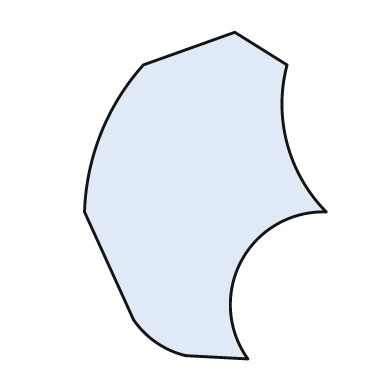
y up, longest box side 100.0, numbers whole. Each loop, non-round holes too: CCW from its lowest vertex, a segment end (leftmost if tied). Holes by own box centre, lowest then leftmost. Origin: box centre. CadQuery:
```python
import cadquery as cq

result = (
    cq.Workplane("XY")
    .moveTo(13.0, -50.0)
    .threePointArc((11.0, -20.0), (37.0, -5.0))
    .threePointArc((25.0, 16.0), (25.0, 40.0))
    .lineTo(9.0, 50.0)
    .lineTo(-19.0, 40.0)
    .threePointArc((-32.0, 19.0), (-37.0, -5.0))
    .lineTo(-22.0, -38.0)
    .threePointArc((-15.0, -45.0), (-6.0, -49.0))
    .close()
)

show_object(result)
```